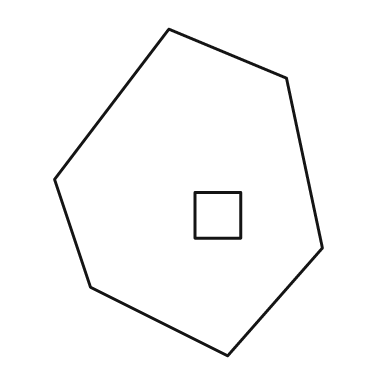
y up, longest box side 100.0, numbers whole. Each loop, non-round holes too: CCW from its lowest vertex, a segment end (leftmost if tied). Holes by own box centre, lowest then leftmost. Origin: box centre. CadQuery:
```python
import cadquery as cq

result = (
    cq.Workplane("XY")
    .moveTo(12.0, -50.0)
    .lineTo(41.0, -17.0)
    .lineTo(30.0, 35.0)
    .lineTo(-6.0, 50.0)
    .lineTo(-41.0, 4.0)
    .lineTo(-30.0, -29.0)
    .close()
    .moveTo(2.0, -14.0)
    .lineTo(16.0, -14.0)
    .lineTo(16.0, 0.0)
    .lineTo(2.0, 0.0)
    .close()
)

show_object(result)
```